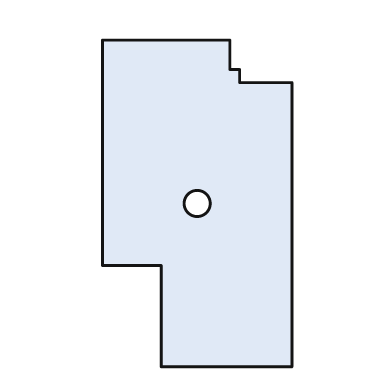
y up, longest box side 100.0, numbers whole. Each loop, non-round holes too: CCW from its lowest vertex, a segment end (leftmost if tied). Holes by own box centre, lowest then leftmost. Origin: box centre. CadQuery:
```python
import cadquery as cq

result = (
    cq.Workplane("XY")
    .moveTo(-11.0, -50.0)
    .lineTo(29.0, -50.0)
    .lineTo(29.0, 37.0)
    .lineTo(13.0, 37.0)
    .lineTo(13.0, 41.0)
    .lineTo(10.0, 41.0)
    .lineTo(10.0, 50.0)
    .lineTo(-29.0, 50.0)
    .lineTo(-29.0, -19.0)
    .lineTo(-11.0, -19.0)
    .close()
    .moveTo(0.0, 0.0)
    .circle(4.0)
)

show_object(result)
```